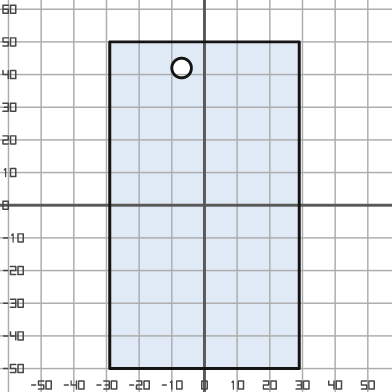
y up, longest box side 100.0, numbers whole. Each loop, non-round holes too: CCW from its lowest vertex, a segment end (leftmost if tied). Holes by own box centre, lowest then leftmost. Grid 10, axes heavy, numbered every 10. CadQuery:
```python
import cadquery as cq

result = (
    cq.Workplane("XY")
    .moveTo(-29.0, -50.0)
    .lineTo(29.0, -50.0)
    .lineTo(29.0, 50.0)
    .lineTo(-29.0, 50.0)
    .close()
    .moveTo(-7.0, 42.0)
    .circle(3.0)
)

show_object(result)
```